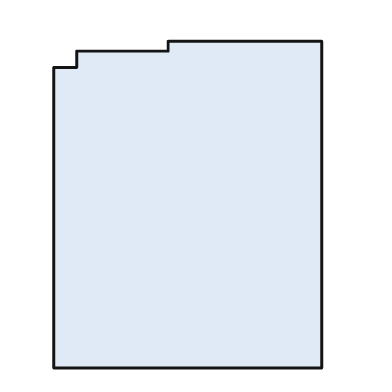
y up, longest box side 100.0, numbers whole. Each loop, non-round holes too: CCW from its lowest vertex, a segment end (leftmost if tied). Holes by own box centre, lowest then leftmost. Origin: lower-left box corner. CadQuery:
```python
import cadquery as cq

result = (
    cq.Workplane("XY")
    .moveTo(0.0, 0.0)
    .lineTo(82.0, 0.0)
    .lineTo(82.0, 100.0)
    .lineTo(35.0, 100.0)
    .lineTo(35.0, 97.0)
    .lineTo(7.0, 97.0)
    .lineTo(7.0, 92.0)
    .lineTo(0.0, 92.0)
    .close()
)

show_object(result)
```